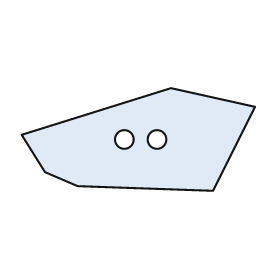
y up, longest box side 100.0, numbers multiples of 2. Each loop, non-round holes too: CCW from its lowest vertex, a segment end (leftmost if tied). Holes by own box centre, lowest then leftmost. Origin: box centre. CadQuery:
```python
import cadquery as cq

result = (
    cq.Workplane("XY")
    .moveTo(32.0, -22.0)
    .lineTo(50.0, 14.0)
    .lineTo(14.0, 22.0)
    .lineTo(-50.0, 2.0)
    .lineTo(-40.0, -14.0)
    .lineTo(-26.0, -20.0)
    .close()
    .moveTo(-6.0, 0.0)
    .circle(4.0)
    .moveTo(8.0, 0.0)
    .circle(4.0)
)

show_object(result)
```